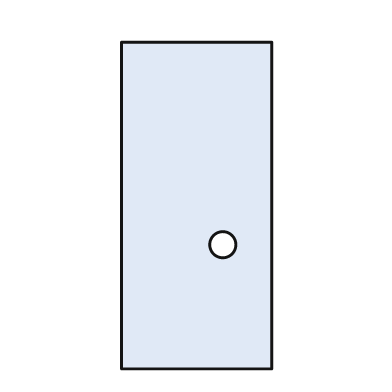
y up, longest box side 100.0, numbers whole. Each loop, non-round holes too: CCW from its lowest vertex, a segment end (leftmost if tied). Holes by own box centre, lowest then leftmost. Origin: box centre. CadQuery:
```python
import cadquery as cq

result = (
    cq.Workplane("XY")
    .moveTo(-23.0, -50.0)
    .lineTo(23.0, -50.0)
    .lineTo(23.0, 50.0)
    .lineTo(-23.0, 50.0)
    .close()
    .moveTo(8.0, -12.0)
    .circle(4.0)
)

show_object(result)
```